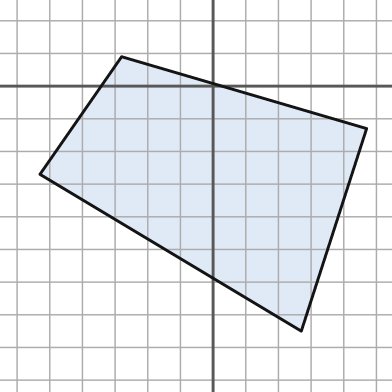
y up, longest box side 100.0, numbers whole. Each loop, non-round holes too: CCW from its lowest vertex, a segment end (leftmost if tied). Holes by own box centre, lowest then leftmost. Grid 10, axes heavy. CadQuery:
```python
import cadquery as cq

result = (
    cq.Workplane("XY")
    .moveTo(27.0, -75.0)
    .lineTo(47.0, -13.0)
    .lineTo(-28.0, 9.0)
    .lineTo(-53.0, -27.0)
    .close()
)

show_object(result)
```